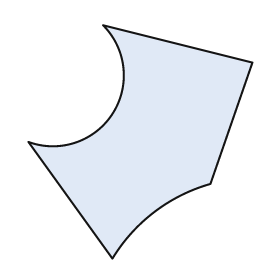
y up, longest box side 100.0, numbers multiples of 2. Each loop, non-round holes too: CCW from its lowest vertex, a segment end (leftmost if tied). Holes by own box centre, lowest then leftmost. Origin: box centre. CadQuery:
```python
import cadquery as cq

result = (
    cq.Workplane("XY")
    .moveTo(-12.0, -50.0)
    .threePointArc((6.0, -30.0), (30.0, -18.0))
    .lineTo(48.0, 34.0)
    .lineTo(-16.0, 50.0)
    .threePointArc((-12.0, 12.0), (-48.0, 0.0))
    .close()
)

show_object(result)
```